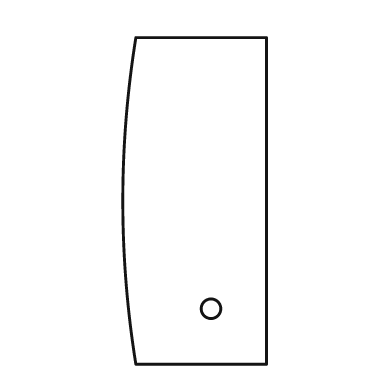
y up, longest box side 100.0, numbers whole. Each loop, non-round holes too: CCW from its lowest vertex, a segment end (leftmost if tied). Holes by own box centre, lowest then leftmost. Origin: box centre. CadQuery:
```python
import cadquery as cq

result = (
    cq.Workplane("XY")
    .moveTo(-18.0, -50.0)
    .lineTo(22.0, -50.0)
    .lineTo(22.0, 50.0)
    .lineTo(-18.0, 50.0)
    .threePointArc((-22.0, 0.0), (-18.0, -50.0))
    .close()
    .moveTo(5.0, -33.0)
    .circle(3.0)
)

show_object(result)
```